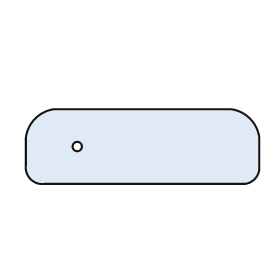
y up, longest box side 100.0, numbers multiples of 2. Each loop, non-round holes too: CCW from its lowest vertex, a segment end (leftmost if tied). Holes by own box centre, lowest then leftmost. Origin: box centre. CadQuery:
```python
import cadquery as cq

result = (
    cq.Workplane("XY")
    .moveTo(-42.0, -16.0)
    .lineTo(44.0, -16.0)
    .threePointArc((48.0, -14.0), (50.0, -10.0))
    .lineTo(50.0, 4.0)
    .threePointArc((46.0, 12.0), (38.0, 16.0))
    .lineTo(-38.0, 16.0)
    .threePointArc((-46.0, 12.0), (-50.0, 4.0))
    .lineTo(-50.0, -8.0)
    .threePointArc((-48.0, -14.0), (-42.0, -16.0))
    .close()
    .moveTo(-28.0, 0.0)
    .circle(2.0)
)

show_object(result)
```